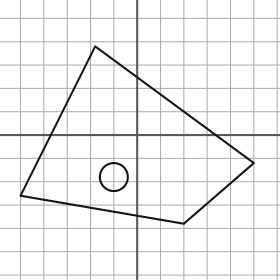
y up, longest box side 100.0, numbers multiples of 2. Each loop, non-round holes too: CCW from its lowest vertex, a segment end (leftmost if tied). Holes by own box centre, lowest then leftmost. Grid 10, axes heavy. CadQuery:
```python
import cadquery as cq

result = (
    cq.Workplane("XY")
    .moveTo(20.0, -38.0)
    .lineTo(50.0, -12.0)
    .lineTo(-18.0, 38.0)
    .lineTo(-50.0, -26.0)
    .close()
    .moveTo(-10.0, -18.0)
    .circle(6.0)
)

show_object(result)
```